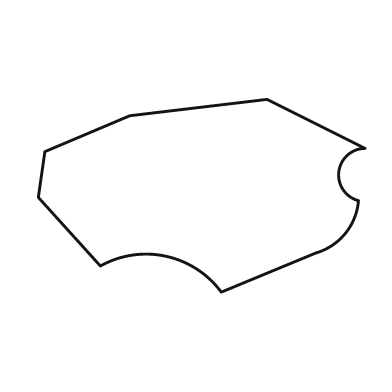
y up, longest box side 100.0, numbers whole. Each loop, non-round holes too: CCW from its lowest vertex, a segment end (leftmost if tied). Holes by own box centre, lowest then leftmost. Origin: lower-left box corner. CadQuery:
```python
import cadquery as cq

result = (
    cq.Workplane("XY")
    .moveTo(56.0, 0.0)
    .lineTo(85.0, 12.0)
    .threePointArc((94.0, 18.0), (98.0, 28.0))
    .threePointArc((92.0, 37.0), (100.0, 44.0))
    .lineTo(70.0, 59.0)
    .lineTo(28.0, 54.0)
    .lineTo(2.0, 43.0)
    .lineTo(0.0, 29.0)
    .lineTo(19.0, 8.0)
    .threePointArc((39.0, 11.0), (56.0, 0.0))
    .close()
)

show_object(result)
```